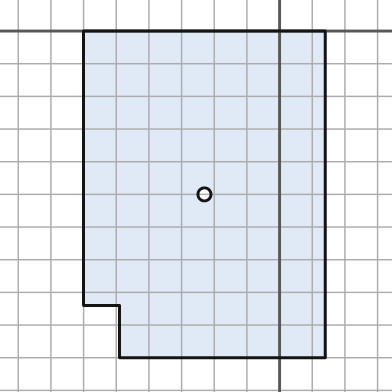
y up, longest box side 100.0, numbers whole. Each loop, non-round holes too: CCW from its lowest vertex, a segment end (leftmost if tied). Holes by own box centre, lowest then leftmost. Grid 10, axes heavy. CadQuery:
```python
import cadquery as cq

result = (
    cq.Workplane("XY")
    .moveTo(-49.0, -100.0)
    .lineTo(14.0, -100.0)
    .lineTo(14.0, 0.0)
    .lineTo(-60.0, 0.0)
    .lineTo(-60.0, -84.0)
    .lineTo(-49.0, -84.0)
    .close()
    .moveTo(-23.0, -50.0)
    .circle(2.0)
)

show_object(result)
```